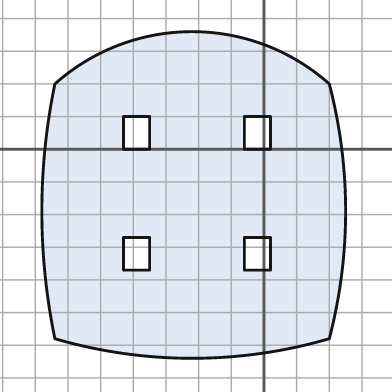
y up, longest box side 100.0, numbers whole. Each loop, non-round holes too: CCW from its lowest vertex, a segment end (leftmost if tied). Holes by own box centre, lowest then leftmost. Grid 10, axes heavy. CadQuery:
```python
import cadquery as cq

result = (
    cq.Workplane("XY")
    .moveTo(-64.0, -58.0)
    .threePointArc((-22.0, -64.0), (20.0, -58.0))
    .threePointArc((25.0, -19.0), (20.0, 20.0))
    .threePointArc((-22.0, 36.0), (-64.0, 20.0))
    .threePointArc((-68.0, -19.0), (-64.0, -58.0))
    .close()
    .moveTo(-43.0, -37.0)
    .lineTo(-35.0, -37.0)
    .lineTo(-35.0, -27.0)
    .lineTo(-43.0, -27.0)
    .close()
    .moveTo(-6.0, -37.0)
    .lineTo(2.0, -37.0)
    .lineTo(2.0, -27.0)
    .lineTo(-6.0, -27.0)
    .close()
    .moveTo(-43.0, 0.0)
    .lineTo(-35.0, 0.0)
    .lineTo(-35.0, 10.0)
    .lineTo(-43.0, 10.0)
    .close()
    .moveTo(-6.0, 0.0)
    .lineTo(2.0, 0.0)
    .lineTo(2.0, 10.0)
    .lineTo(-6.0, 10.0)
    .close()
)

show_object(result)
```